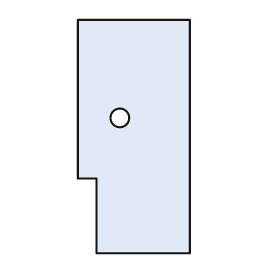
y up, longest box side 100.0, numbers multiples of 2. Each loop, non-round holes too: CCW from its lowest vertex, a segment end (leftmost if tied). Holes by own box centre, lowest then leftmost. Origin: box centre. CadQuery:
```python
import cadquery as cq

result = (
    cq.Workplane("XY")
    .moveTo(-16.0, -50.0)
    .lineTo(24.0, -50.0)
    .lineTo(24.0, 50.0)
    .lineTo(-24.0, 50.0)
    .lineTo(-24.0, -18.0)
    .lineTo(-16.0, -18.0)
    .close()
    .moveTo(-6.0, 8.0)
    .circle(4.0)
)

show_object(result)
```